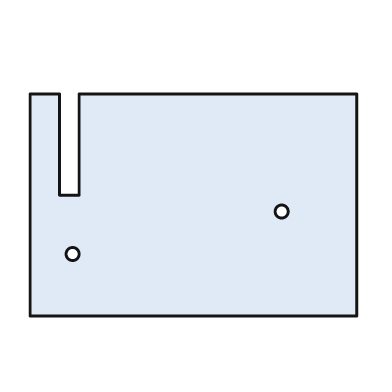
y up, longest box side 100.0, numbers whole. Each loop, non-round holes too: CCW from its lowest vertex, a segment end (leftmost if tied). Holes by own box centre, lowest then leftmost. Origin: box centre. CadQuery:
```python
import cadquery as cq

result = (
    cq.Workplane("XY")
    .moveTo(-50.0, -34.0)
    .lineTo(50.0, -34.0)
    .lineTo(50.0, 34.0)
    .lineTo(-35.0, 34.0)
    .lineTo(-35.0, 3.0)
    .lineTo(-41.0, 3.0)
    .lineTo(-41.0, 34.0)
    .lineTo(-50.0, 34.0)
    .close()
    .moveTo(-37.0, -15.0)
    .circle(2.0)
    .moveTo(27.0, -2.0)
    .circle(2.0)
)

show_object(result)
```